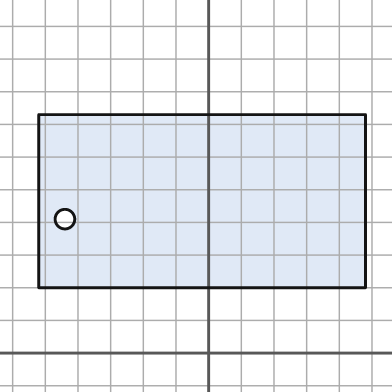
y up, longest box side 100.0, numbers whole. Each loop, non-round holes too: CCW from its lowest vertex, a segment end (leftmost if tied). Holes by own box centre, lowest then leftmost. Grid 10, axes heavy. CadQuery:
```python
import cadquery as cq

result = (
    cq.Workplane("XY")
    .moveTo(-52.0, 20.0)
    .lineTo(48.0, 20.0)
    .lineTo(48.0, 73.0)
    .lineTo(-52.0, 73.0)
    .close()
    .moveTo(-44.0, 41.0)
    .circle(3.0)
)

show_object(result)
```